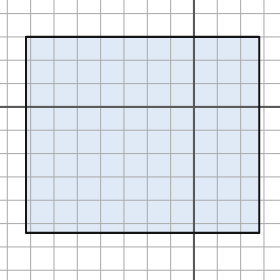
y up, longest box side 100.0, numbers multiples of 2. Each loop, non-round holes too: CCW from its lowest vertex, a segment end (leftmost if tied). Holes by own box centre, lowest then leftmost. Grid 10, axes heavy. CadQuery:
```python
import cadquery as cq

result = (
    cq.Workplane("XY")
    .moveTo(-72.0, -54.0)
    .lineTo(28.0, -54.0)
    .lineTo(28.0, 30.0)
    .lineTo(-72.0, 30.0)
    .close()
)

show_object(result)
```